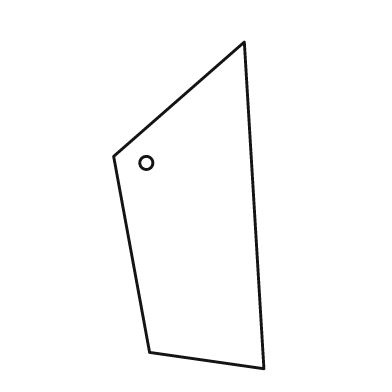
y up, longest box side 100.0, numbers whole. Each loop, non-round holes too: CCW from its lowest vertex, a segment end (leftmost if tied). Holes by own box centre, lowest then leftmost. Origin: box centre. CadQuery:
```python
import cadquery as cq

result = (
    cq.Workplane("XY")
    .moveTo(23.0, -50.0)
    .lineTo(17.0, 50.0)
    .lineTo(-23.0, 15.0)
    .lineTo(-12.0, -45.0)
    .close()
    .moveTo(-13.0, 13.0)
    .circle(2.0)
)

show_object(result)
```